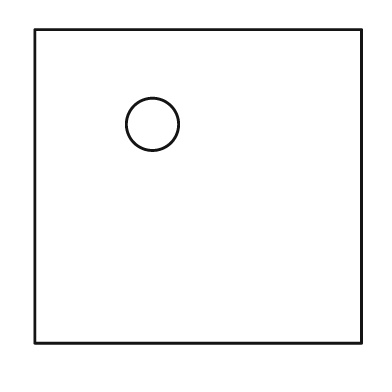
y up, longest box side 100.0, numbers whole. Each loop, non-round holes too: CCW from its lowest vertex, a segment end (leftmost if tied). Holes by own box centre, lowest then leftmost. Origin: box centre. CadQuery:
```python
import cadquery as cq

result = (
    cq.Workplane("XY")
    .moveTo(-50.0, -48.0)
    .lineTo(50.0, -48.0)
    .lineTo(50.0, 48.0)
    .lineTo(-50.0, 48.0)
    .close()
    .moveTo(-14.0, 19.0)
    .circle(8.0)
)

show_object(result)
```